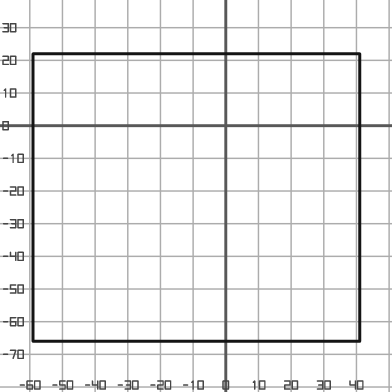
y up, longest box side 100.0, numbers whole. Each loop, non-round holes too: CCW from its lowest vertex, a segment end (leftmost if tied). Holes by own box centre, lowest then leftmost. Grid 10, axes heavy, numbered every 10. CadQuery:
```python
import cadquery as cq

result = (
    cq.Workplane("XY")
    .moveTo(-59.0, -66.0)
    .lineTo(41.0, -66.0)
    .lineTo(41.0, 22.0)
    .lineTo(-59.0, 22.0)
    .close()
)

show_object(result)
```